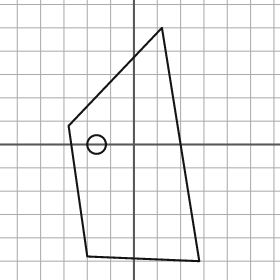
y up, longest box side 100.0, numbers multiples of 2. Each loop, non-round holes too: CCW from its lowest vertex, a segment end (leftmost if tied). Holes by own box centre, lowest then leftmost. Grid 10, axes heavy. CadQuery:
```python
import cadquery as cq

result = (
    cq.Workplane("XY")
    .moveTo(28.0, -50.0)
    .lineTo(12.0, 50.0)
    .lineTo(-28.0, 8.0)
    .lineTo(-20.0, -48.0)
    .close()
    .moveTo(-16.0, 0.0)
    .circle(4.0)
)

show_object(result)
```